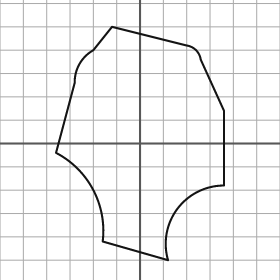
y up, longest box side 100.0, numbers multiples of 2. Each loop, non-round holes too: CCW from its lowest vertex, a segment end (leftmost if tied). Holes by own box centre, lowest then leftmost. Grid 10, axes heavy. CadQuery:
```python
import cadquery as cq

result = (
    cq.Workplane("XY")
    .moveTo(12.0, -50.0)
    .threePointArc((16.0, -28.0), (36.0, -18.0))
    .lineTo(36.0, 14.0)
    .lineTo(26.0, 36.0)
    .threePointArc((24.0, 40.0), (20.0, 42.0))
    .lineTo(-12.0, 50.0)
    .lineTo(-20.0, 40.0)
    .threePointArc((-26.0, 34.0), (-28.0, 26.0))
    .lineTo(-36.0, -4.0)
    .threePointArc((-20.0, -20.0), (-16.0, -42.0))
    .close()
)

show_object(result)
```